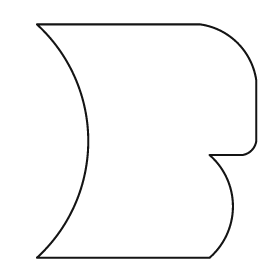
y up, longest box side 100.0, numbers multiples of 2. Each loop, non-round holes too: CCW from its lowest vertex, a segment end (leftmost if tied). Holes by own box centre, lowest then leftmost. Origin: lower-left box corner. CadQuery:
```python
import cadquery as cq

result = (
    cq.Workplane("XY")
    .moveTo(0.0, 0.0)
    .lineTo(74.0, 0.0)
    .threePointArc((84.0, 22.0), (74.0, 44.0))
    .lineTo(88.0, 44.0)
    .threePointArc((92.0, 46.0), (94.0, 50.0))
    .lineTo(94.0, 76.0)
    .threePointArc((86.0, 92.0), (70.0, 100.0))
    .lineTo(0.0, 100.0)
    .threePointArc((22.0, 50.0), (0.0, 0.0))
    .close()
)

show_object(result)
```